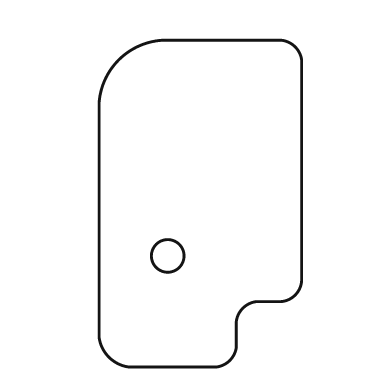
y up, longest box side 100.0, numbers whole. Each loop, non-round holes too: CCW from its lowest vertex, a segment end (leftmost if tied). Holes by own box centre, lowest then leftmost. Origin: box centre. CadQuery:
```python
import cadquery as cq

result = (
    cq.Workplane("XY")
    .moveTo(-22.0, -50.0)
    .lineTo(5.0, -50.0)
    .threePointArc((9.0, -48.0), (11.0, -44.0))
    .lineTo(11.0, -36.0)
    .threePointArc((13.0, -32.0), (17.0, -30.0))
    .lineTo(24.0, -30.0)
    .threePointArc((29.0, -28.0), (31.0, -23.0))
    .lineTo(31.0, 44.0)
    .threePointArc((29.0, 48.0), (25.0, 50.0))
    .lineTo(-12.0, 50.0)
    .threePointArc((-25.0, 44.0), (-31.0, 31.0))
    .lineTo(-31.0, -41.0)
    .threePointArc((-28.0, -47.0), (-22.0, -50.0))
    .close()
    .moveTo(-10.0, -16.0)
    .circle(5.0)
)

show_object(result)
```